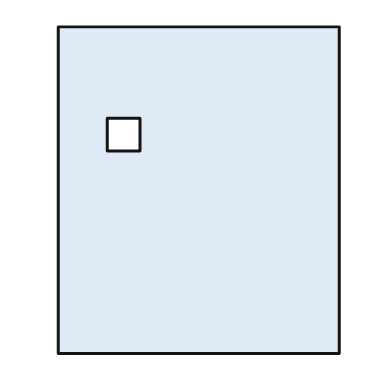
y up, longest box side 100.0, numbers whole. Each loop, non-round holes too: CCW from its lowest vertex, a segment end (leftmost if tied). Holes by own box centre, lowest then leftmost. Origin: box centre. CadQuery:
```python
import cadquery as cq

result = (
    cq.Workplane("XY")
    .moveTo(-43.0, -50.0)
    .lineTo(43.0, -50.0)
    .lineTo(43.0, 50.0)
    .lineTo(-43.0, 50.0)
    .close()
    .moveTo(-28.0, 12.0)
    .lineTo(-18.0, 12.0)
    .lineTo(-18.0, 22.0)
    .lineTo(-28.0, 22.0)
    .close()
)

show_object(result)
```